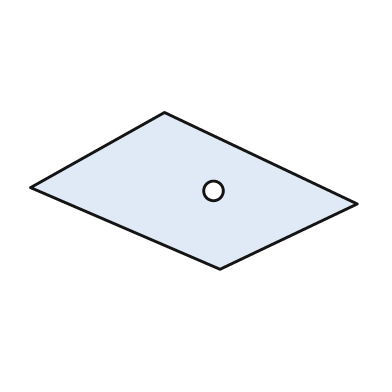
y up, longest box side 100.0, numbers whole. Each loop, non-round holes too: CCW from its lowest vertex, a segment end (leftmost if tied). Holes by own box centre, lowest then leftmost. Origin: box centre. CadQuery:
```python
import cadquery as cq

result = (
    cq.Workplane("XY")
    .moveTo(8.0, -24.0)
    .lineTo(50.0, -4.0)
    .lineTo(-9.0, 24.0)
    .lineTo(-50.0, 1.0)
    .close()
    .moveTo(6.0, 0.0)
    .circle(3.0)
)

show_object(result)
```